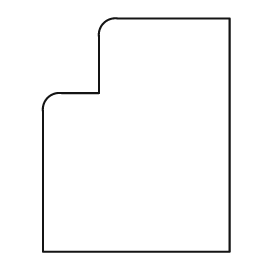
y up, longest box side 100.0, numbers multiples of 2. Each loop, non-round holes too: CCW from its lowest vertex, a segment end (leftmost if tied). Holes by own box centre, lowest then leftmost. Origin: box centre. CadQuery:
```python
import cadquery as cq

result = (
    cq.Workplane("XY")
    .moveTo(-40.0, -50.0)
    .lineTo(40.0, -50.0)
    .lineTo(40.0, 50.0)
    .lineTo(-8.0, 50.0)
    .threePointArc((-14.0, 48.0), (-16.0, 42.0))
    .lineTo(-16.0, 18.0)
    .lineTo(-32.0, 18.0)
    .threePointArc((-38.0, 16.0), (-40.0, 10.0))
    .close()
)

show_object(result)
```